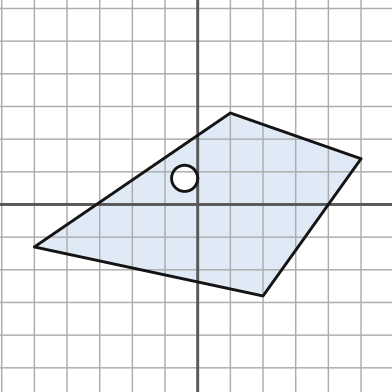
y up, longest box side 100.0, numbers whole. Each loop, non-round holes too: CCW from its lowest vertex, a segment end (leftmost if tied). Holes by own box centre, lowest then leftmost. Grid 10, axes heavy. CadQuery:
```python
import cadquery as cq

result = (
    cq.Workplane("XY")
    .moveTo(20.0, -28.0)
    .lineTo(50.0, 14.0)
    .lineTo(10.0, 28.0)
    .lineTo(-50.0, -13.0)
    .close()
    .moveTo(-4.0, 8.0)
    .circle(4.0)
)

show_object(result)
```